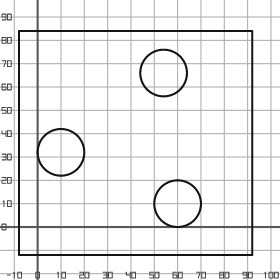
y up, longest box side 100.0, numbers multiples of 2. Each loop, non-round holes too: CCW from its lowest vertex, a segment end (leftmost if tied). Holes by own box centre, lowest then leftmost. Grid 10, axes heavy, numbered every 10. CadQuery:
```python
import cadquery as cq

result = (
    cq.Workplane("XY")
    .moveTo(-8.0, -12.0)
    .lineTo(92.0, -12.0)
    .lineTo(92.0, 84.0)
    .lineTo(-8.0, 84.0)
    .close()
    .moveTo(60.0, 10.0)
    .circle(10.0)
    .moveTo(10.0, 32.0)
    .circle(10.0)
    .moveTo(54.0, 66.0)
    .circle(10.0)
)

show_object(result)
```